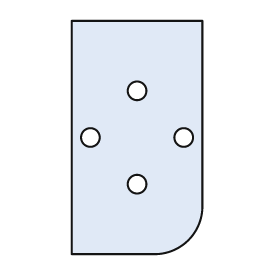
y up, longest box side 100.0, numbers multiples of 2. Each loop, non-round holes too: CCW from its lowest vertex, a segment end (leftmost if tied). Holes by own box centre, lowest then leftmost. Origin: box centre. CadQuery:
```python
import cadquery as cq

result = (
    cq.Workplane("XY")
    .moveTo(-28.0, -50.0)
    .lineTo(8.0, -50.0)
    .threePointArc((22.0, -44.0), (28.0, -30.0))
    .lineTo(28.0, 50.0)
    .lineTo(-28.0, 50.0)
    .close()
    .moveTo(0.0, -20.0)
    .circle(4.0)
    .moveTo(-20.0, 0.0)
    .circle(4.0)
    .moveTo(20.0, 0.0)
    .circle(4.0)
    .moveTo(0.0, 20.0)
    .circle(4.0)
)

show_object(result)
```